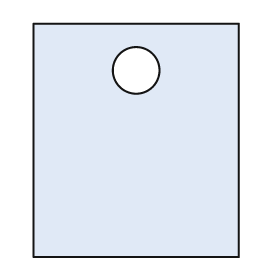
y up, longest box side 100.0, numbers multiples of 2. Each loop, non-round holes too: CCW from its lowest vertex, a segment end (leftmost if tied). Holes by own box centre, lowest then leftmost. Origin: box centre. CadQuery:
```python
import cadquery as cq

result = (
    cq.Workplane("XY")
    .moveTo(-44.0, -50.0)
    .lineTo(44.0, -50.0)
    .lineTo(44.0, 50.0)
    .lineTo(-44.0, 50.0)
    .close()
    .moveTo(0.0, 30.0)
    .circle(10.0)
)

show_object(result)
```